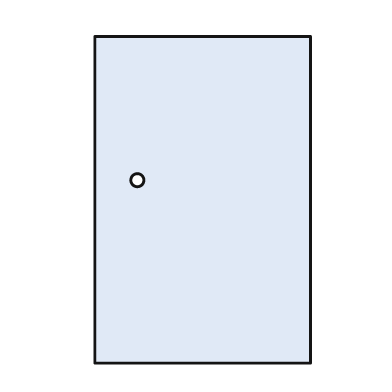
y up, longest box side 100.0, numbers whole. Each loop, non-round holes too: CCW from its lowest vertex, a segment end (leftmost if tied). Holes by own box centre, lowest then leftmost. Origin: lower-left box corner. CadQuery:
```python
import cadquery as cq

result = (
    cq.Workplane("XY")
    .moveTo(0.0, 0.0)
    .lineTo(66.0, 0.0)
    .lineTo(66.0, 100.0)
    .lineTo(0.0, 100.0)
    .close()
    .moveTo(13.0, 56.0)
    .circle(2.0)
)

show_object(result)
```